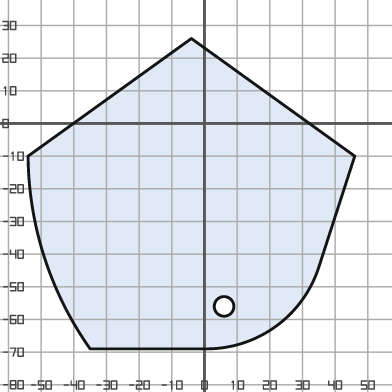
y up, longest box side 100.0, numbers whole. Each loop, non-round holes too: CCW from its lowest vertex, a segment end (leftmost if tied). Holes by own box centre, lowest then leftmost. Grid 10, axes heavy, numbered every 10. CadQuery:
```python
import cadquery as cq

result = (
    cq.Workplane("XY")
    .moveTo(-35.0, -69.0)
    .lineTo(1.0, -69.0)
    .threePointArc((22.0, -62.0), (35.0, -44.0))
    .lineTo(46.0, -10.0)
    .lineTo(-4.0, 26.0)
    .lineTo(-54.0, -10.0)
    .threePointArc((-49.0, -41.0), (-35.0, -69.0))
    .close()
    .moveTo(6.0, -56.0)
    .circle(3.0)
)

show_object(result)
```